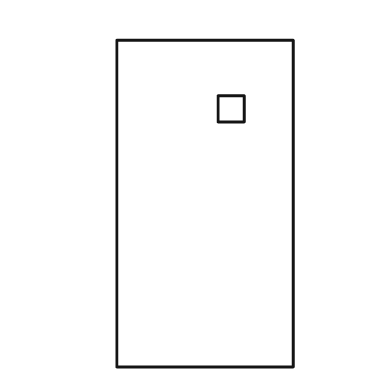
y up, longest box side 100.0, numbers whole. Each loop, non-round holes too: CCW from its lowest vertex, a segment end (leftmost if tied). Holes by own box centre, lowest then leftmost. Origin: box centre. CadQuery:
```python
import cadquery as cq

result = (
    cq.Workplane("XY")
    .moveTo(-27.0, -50.0)
    .lineTo(27.0, -50.0)
    .lineTo(27.0, 50.0)
    .lineTo(-27.0, 50.0)
    .close()
    .moveTo(4.0, 25.0)
    .lineTo(12.0, 25.0)
    .lineTo(12.0, 33.0)
    .lineTo(4.0, 33.0)
    .close()
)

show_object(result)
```